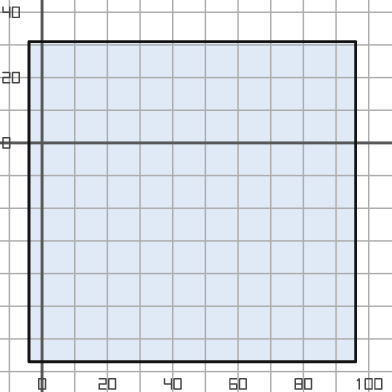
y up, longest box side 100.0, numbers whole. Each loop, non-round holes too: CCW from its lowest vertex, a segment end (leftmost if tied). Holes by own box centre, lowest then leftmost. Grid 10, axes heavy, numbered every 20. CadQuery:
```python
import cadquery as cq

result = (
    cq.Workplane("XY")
    .moveTo(-4.0, -67.0)
    .lineTo(96.0, -67.0)
    .lineTo(96.0, 31.0)
    .lineTo(-4.0, 31.0)
    .close()
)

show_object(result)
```